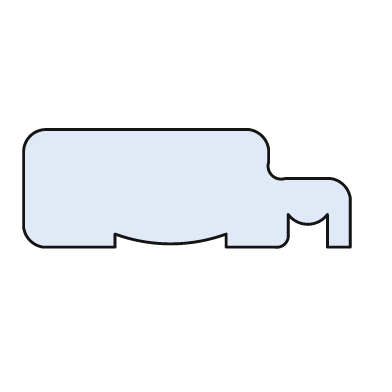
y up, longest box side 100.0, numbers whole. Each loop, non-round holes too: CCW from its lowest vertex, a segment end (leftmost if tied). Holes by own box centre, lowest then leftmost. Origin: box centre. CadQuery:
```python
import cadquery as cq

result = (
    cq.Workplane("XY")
    .moveTo(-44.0, -18.0)
    .lineTo(-22.0, -18.0)
    .lineTo(-22.0, -14.0)
    .threePointArc((-5.0, -17.0), (12.0, -14.0))
    .lineTo(12.0, -18.0)
    .lineTo(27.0, -18.0)
    .threePointArc((30.0, -17.0), (31.0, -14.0))
    .lineTo(31.0, -8.0)
    .threePointArc((37.0, -11.0), (43.0, -8.0))
    .lineTo(43.0, -18.0)
    .lineTo(50.0, -18.0)
    .lineTo(50.0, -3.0)
    .threePointArc((48.0, 1.0), (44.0, 3.0))
    .lineTo(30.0, 3.0)
    .threePointArc((26.0, 4.0), (25.0, 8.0))
    .lineTo(25.0, 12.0)
    .threePointArc((23.0, 16.0), (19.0, 18.0))
    .lineTo(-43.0, 18.0)
    .threePointArc((-48.0, 16.0), (-50.0, 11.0))
    .lineTo(-50.0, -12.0)
    .threePointArc((-48.0, -16.0), (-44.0, -18.0))
    .close()
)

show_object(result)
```